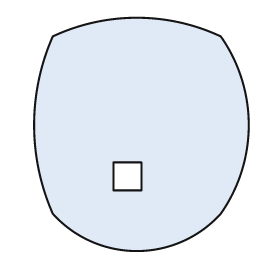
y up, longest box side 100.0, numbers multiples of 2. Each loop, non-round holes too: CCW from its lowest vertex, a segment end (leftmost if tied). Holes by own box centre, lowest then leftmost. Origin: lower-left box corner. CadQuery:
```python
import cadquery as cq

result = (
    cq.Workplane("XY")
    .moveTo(8.0, 16.0)
    .threePointArc((44.0, 0.0), (80.0, 16.0))
    .threePointArc((92.0, 54.0), (80.0, 92.0))
    .threePointArc((44.0, 100.0), (8.0, 92.0))
    .threePointArc((0.0, 54.0), (8.0, 16.0))
    .close()
    .moveTo(34.0, 26.0)
    .lineTo(46.0, 26.0)
    .lineTo(46.0, 38.0)
    .lineTo(34.0, 38.0)
    .close()
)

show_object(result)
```